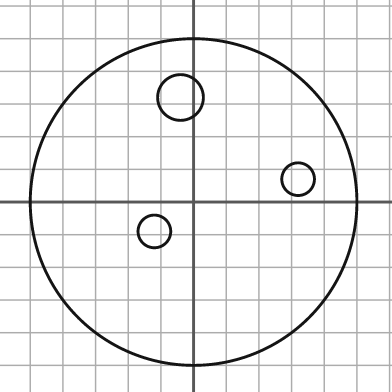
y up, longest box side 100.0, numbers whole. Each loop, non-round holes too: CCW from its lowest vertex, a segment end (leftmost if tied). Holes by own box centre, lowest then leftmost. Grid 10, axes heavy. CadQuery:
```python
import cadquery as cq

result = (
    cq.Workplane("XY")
    .moveTo(0.0, 0.0)
    .circle(50.0)
    .moveTo(-12.0, -9.0)
    .circle(5.0)
    .moveTo(32.0, 7.0)
    .circle(5.0)
    .moveTo(-4.0, 32.0)
    .circle(7.0)
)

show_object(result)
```